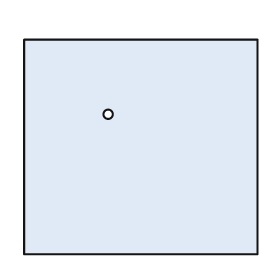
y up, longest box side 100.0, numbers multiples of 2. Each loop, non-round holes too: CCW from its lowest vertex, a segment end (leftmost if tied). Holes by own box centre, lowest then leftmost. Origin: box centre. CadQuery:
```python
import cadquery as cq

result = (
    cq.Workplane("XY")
    .moveTo(-50.0, -46.0)
    .lineTo(50.0, -46.0)
    .lineTo(50.0, 46.0)
    .lineTo(-50.0, 46.0)
    .close()
    .moveTo(-14.0, 14.0)
    .circle(2.0)
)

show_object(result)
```